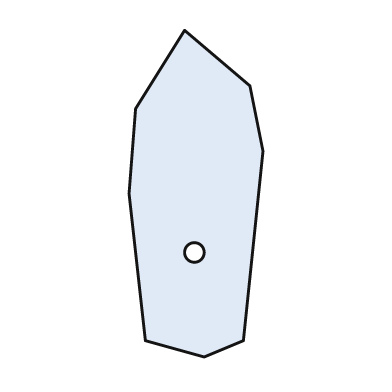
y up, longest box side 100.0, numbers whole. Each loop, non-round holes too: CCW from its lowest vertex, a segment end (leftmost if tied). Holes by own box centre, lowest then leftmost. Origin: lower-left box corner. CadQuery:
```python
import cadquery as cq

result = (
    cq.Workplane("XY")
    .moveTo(23.0, 0.0)
    .lineTo(35.0, 5.0)
    .lineTo(41.0, 63.0)
    .lineTo(37.0, 83.0)
    .lineTo(17.0, 100.0)
    .lineTo(2.0, 76.0)
    .lineTo(0.0, 50.0)
    .lineTo(5.0, 5.0)
    .close()
    .moveTo(20.0, 32.0)
    .circle(3.0)
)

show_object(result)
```